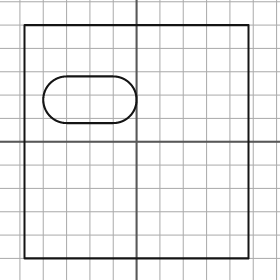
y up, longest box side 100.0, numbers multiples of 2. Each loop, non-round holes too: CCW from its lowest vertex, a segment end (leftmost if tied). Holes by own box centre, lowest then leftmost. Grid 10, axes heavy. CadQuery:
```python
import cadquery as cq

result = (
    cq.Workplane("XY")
    .moveTo(-48.0, -50.0)
    .lineTo(48.0, -50.0)
    .lineTo(48.0, 50.0)
    .lineTo(-48.0, 50.0)
    .close()
    .moveTo(-30.0, 8.0)
    .lineTo(-10.0, 8.0)
    .threePointArc((0.0, 18.0), (-10.0, 28.0))
    .lineTo(-30.0, 28.0)
    .threePointArc((-40.0, 18.0), (-30.0, 8.0))
    .close()
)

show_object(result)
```